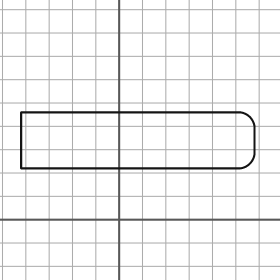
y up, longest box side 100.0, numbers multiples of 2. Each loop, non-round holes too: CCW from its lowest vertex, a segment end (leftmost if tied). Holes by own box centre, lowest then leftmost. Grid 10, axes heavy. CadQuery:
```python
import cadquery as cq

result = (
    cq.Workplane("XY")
    .moveTo(-42.0, 22.0)
    .lineTo(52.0, 22.0)
    .threePointArc((56.0, 24.0), (58.0, 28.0))
    .lineTo(58.0, 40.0)
    .threePointArc((56.0, 44.0), (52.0, 46.0))
    .lineTo(-42.0, 46.0)
    .close()
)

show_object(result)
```